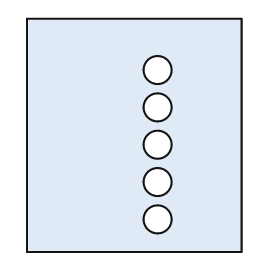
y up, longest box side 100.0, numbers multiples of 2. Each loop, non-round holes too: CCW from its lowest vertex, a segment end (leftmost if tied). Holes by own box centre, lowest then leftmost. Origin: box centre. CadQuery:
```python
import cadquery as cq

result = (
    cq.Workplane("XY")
    .moveTo(-46.0, -50.0)
    .lineTo(46.0, -50.0)
    .lineTo(46.0, 50.0)
    .lineTo(-46.0, 50.0)
    .close()
    .moveTo(10.0, -36.0)
    .circle(6.0)
    .moveTo(10.0, -20.0)
    .circle(6.0)
    .moveTo(10.0, -4.0)
    .circle(6.0)
    .moveTo(10.0, 12.0)
    .circle(6.0)
    .moveTo(10.0, 28.0)
    .circle(6.0)
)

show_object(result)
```